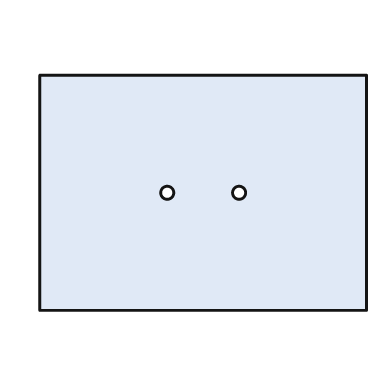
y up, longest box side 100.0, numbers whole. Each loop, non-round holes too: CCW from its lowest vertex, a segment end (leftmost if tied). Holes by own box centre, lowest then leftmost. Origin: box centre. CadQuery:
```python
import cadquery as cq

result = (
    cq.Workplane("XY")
    .moveTo(-50.0, -36.0)
    .lineTo(50.0, -36.0)
    .lineTo(50.0, 36.0)
    .lineTo(-50.0, 36.0)
    .close()
    .moveTo(-11.0, 0.0)
    .circle(2.0)
    .moveTo(11.0, 0.0)
    .circle(2.0)
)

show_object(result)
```